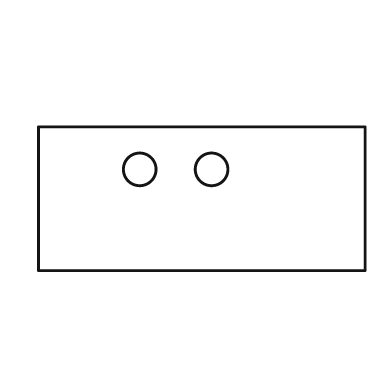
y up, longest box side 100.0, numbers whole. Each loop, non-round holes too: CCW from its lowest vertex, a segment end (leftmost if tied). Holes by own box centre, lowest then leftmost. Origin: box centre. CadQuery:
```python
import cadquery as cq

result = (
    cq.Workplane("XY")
    .moveTo(-50.0, -22.0)
    .lineTo(50.0, -22.0)
    .lineTo(50.0, 22.0)
    .lineTo(-50.0, 22.0)
    .close()
    .moveTo(-19.0, 9.0)
    .circle(5.0)
    .moveTo(3.0, 9.0)
    .circle(5.0)
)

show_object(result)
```